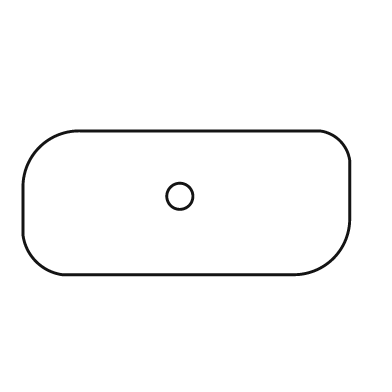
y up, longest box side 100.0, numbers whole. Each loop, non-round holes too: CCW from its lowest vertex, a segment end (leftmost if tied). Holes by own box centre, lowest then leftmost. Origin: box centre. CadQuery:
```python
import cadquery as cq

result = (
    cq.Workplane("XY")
    .moveTo(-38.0, -22.0)
    .lineTo(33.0, -22.0)
    .threePointArc((45.0, -17.0), (50.0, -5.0))
    .lineTo(50.0, 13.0)
    .threePointArc((47.0, 19.0), (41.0, 22.0))
    .lineTo(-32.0, 22.0)
    .threePointArc((-45.0, 17.0), (-50.0, 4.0))
    .lineTo(-50.0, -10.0)
    .threePointArc((-46.0, -18.0), (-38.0, -22.0))
    .close()
    .moveTo(-2.0, 2.0)
    .circle(4.0)
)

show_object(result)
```